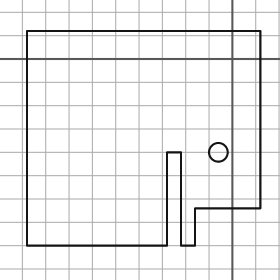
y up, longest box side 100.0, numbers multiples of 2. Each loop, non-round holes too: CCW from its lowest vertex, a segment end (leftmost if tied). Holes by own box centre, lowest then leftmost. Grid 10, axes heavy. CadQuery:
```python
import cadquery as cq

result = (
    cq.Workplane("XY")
    .moveTo(-88.0, -80.0)
    .lineTo(-28.0, -80.0)
    .lineTo(-28.0, -40.0)
    .lineTo(-22.0, -40.0)
    .lineTo(-22.0, -80.0)
    .lineTo(-16.0, -80.0)
    .lineTo(-16.0, -64.0)
    .lineTo(12.0, -64.0)
    .lineTo(12.0, 12.0)
    .lineTo(-88.0, 12.0)
    .close()
    .moveTo(-6.0, -40.0)
    .circle(4.0)
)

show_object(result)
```